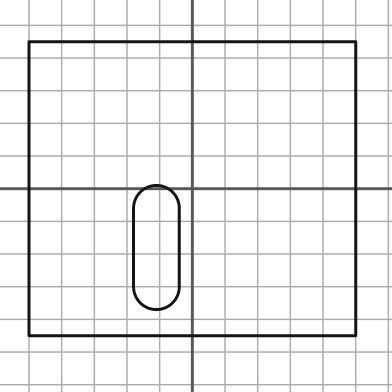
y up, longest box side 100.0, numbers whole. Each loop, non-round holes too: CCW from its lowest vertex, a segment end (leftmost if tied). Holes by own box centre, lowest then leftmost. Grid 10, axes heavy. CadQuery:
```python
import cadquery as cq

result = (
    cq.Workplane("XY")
    .moveTo(-50.0, -45.0)
    .lineTo(50.0, -45.0)
    .lineTo(50.0, 45.0)
    .lineTo(-50.0, 45.0)
    .close()
    .moveTo(-18.0, -30.0)
    .threePointArc((-11.0, -37.0), (-4.0, -30.0))
    .lineTo(-4.0, -6.0)
    .threePointArc((-11.0, 1.0), (-18.0, -6.0))
    .close()
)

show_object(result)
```